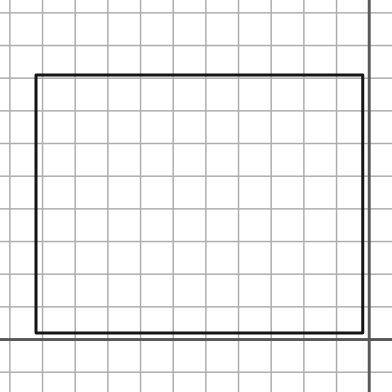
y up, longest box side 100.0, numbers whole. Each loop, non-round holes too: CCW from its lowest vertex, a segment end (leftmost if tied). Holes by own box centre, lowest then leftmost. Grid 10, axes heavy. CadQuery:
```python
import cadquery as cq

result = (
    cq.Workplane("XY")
    .moveTo(-102.0, 2.0)
    .lineTo(-2.0, 2.0)
    .lineTo(-2.0, 81.0)
    .lineTo(-102.0, 81.0)
    .close()
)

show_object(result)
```